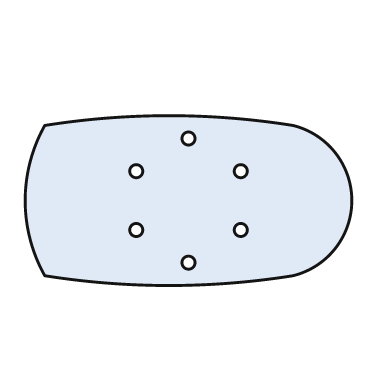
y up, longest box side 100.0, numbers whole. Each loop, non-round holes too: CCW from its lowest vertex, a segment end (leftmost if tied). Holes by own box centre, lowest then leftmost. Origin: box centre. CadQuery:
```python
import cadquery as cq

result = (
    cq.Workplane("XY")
    .moveTo(-44.0, -23.0)
    .threePointArc((-6.0, -26.0), (32.0, -23.0))
    .threePointArc((50.0, 0.0), (32.0, 23.0))
    .threePointArc((-6.0, 26.0), (-44.0, 23.0))
    .threePointArc((-50.0, 0.0), (-44.0, -23.0))
    .close()
    .moveTo(0.0, -19.0)
    .circle(2.0)
    .moveTo(-16.0, -9.0)
    .circle(2.0)
    .moveTo(16.0, -9.0)
    .circle(2.0)
    .moveTo(-16.0, 9.0)
    .circle(2.0)
    .moveTo(16.0, 9.0)
    .circle(2.0)
    .moveTo(0.0, 19.0)
    .circle(2.0)
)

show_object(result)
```